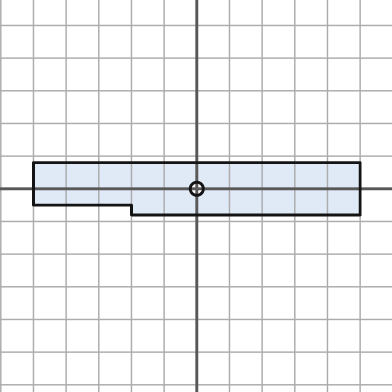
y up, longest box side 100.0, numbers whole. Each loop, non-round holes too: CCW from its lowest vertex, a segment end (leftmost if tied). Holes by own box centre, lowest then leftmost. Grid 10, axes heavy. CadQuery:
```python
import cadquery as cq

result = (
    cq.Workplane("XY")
    .moveTo(-20.0, -8.0)
    .lineTo(50.0, -8.0)
    .lineTo(50.0, 8.0)
    .lineTo(-50.0, 8.0)
    .lineTo(-50.0, -5.0)
    .lineTo(-20.0, -5.0)
    .close()
    .moveTo(0.0, 0.0)
    .circle(2.0)
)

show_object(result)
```